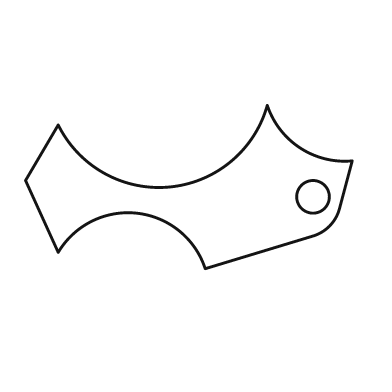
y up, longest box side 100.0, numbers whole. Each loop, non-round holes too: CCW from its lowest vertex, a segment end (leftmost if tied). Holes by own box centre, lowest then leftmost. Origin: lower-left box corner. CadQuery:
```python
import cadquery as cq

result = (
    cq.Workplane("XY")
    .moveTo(55.0, 0.0)
    .lineTo(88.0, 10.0)
    .threePointArc((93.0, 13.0), (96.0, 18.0))
    .lineTo(100.0, 33.0)
    .threePointArc((84.0, 37.0), (74.0, 50.0))
    .threePointArc((44.0, 25.0), (10.0, 44.0))
    .lineTo(0.0, 27.0)
    .lineTo(10.0, 5.0)
    .threePointArc((34.0, 17.0), (55.0, 0.0))
    .close()
    .moveTo(88.0, 22.0)
    .circle(5.0)
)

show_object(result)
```